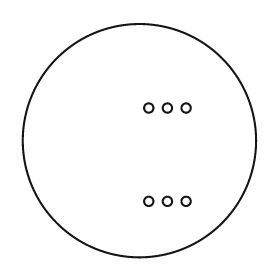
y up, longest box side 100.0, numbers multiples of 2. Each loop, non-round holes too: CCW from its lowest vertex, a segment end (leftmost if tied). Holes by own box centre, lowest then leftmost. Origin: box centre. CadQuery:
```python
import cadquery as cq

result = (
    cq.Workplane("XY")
    .moveTo(0.0, 0.0)
    .circle(50.0)
    .moveTo(4.0, -26.0)
    .circle(2.0)
    .moveTo(12.0, -26.0)
    .circle(2.0)
    .moveTo(20.0, -26.0)
    .circle(2.0)
    .moveTo(4.0, 14.0)
    .circle(2.0)
    .moveTo(12.0, 14.0)
    .circle(2.0)
    .moveTo(20.0, 14.0)
    .circle(2.0)
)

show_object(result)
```